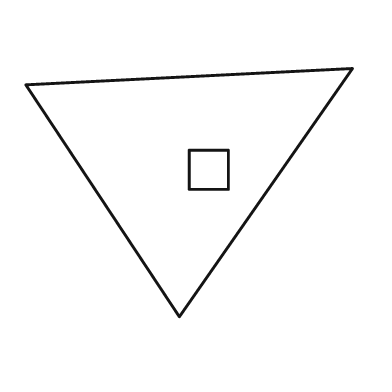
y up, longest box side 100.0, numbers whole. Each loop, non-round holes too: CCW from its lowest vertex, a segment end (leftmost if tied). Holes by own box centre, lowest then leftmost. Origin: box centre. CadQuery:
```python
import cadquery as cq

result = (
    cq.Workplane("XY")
    .moveTo(-3.0, -38.0)
    .lineTo(50.0, 38.0)
    .lineTo(-50.0, 33.0)
    .close()
    .moveTo(0.0, 1.0)
    .lineTo(12.0, 1.0)
    .lineTo(12.0, 13.0)
    .lineTo(0.0, 13.0)
    .close()
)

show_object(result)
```